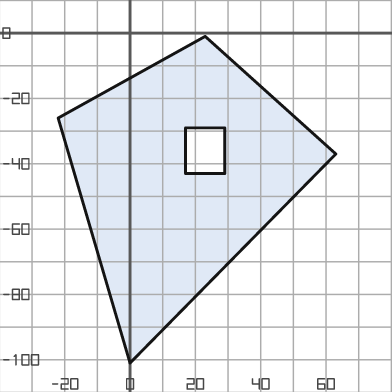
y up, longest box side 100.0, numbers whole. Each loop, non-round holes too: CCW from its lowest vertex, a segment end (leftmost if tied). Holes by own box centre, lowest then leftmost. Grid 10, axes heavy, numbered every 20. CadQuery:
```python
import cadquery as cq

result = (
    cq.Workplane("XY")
    .moveTo(0.0, -101.0)
    .lineTo(63.0, -37.0)
    .lineTo(23.0, -1.0)
    .lineTo(-22.0, -26.0)
    .close()
    .moveTo(17.0, -43.0)
    .lineTo(29.0, -43.0)
    .lineTo(29.0, -29.0)
    .lineTo(17.0, -29.0)
    .close()
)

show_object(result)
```